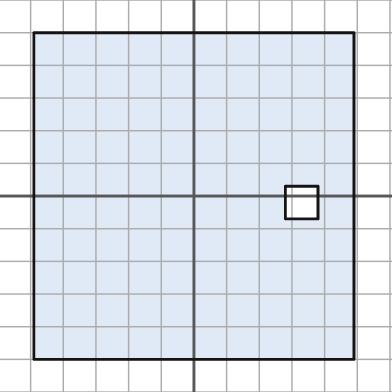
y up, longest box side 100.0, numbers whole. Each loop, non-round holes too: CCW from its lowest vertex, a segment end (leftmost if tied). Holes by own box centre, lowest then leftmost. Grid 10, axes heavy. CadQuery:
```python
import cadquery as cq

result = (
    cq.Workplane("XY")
    .moveTo(-49.0, -50.0)
    .lineTo(49.0, -50.0)
    .lineTo(49.0, 50.0)
    .lineTo(-49.0, 50.0)
    .close()
    .moveTo(28.0, -7.0)
    .lineTo(38.0, -7.0)
    .lineTo(38.0, 3.0)
    .lineTo(28.0, 3.0)
    .close()
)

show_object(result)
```